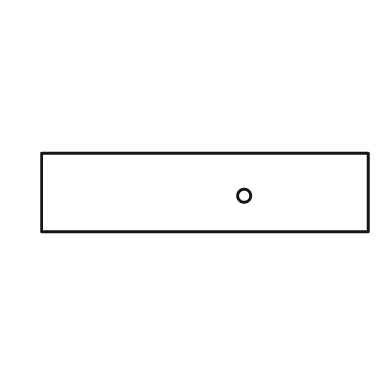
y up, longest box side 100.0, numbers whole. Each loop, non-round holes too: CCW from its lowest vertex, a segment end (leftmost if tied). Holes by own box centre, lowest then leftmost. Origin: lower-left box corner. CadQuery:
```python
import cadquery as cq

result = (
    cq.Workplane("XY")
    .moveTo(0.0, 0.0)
    .lineTo(100.0, 0.0)
    .lineTo(100.0, 24.0)
    .lineTo(0.0, 24.0)
    .close()
    .moveTo(62.0, 11.0)
    .circle(2.0)
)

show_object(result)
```